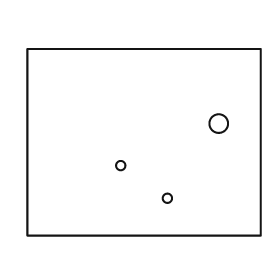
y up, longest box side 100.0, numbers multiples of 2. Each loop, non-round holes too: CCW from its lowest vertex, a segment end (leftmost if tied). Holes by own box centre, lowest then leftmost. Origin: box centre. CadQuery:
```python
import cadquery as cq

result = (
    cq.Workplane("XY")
    .moveTo(-50.0, -40.0)
    .lineTo(50.0, -40.0)
    .lineTo(50.0, 40.0)
    .lineTo(-50.0, 40.0)
    .close()
    .moveTo(10.0, -24.0)
    .circle(2.0)
    .moveTo(-10.0, -10.0)
    .circle(2.0)
    .moveTo(32.0, 8.0)
    .circle(4.0)
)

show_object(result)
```